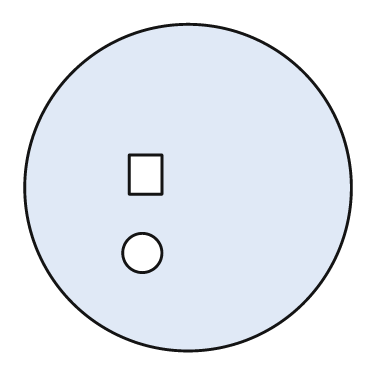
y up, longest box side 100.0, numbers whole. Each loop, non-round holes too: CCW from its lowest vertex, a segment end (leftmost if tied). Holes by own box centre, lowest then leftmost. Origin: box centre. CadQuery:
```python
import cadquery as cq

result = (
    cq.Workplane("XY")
    .moveTo(0.0, 0.0)
    .circle(50.0)
    .moveTo(-14.0, -20.0)
    .circle(6.0)
    .moveTo(-18.0, -2.0)
    .lineTo(-8.0, -2.0)
    .lineTo(-8.0, 10.0)
    .lineTo(-18.0, 10.0)
    .close()
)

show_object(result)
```